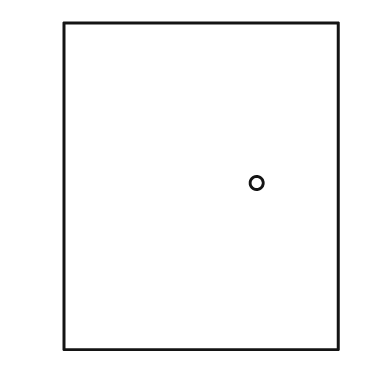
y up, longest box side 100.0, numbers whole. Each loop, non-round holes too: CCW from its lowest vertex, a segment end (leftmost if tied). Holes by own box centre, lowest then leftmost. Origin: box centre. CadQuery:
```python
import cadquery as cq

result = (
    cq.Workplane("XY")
    .moveTo(-42.0, -50.0)
    .lineTo(42.0, -50.0)
    .lineTo(42.0, 50.0)
    .lineTo(-42.0, 50.0)
    .close()
    .moveTo(17.0, 1.0)
    .circle(2.0)
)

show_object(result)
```